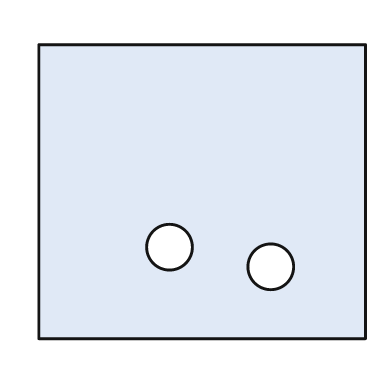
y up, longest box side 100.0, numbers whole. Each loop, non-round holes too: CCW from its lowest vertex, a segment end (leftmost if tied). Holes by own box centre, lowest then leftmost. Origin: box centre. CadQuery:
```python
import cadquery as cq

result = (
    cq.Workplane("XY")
    .moveTo(-50.0, -45.0)
    .lineTo(50.0, -45.0)
    .lineTo(50.0, 45.0)
    .lineTo(-50.0, 45.0)
    .close()
    .moveTo(21.0, -23.0)
    .circle(7.0)
    .moveTo(-10.0, -17.0)
    .circle(7.0)
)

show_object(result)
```